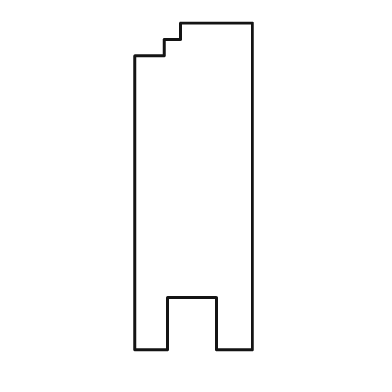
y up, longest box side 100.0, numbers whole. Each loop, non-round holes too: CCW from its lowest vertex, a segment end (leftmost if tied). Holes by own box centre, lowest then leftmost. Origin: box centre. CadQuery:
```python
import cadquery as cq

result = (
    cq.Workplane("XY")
    .moveTo(-18.0, -50.0)
    .lineTo(-8.0, -50.0)
    .lineTo(-8.0, -34.0)
    .lineTo(7.0, -34.0)
    .lineTo(7.0, -50.0)
    .lineTo(18.0, -50.0)
    .lineTo(18.0, 50.0)
    .lineTo(-4.0, 50.0)
    .lineTo(-4.0, 45.0)
    .lineTo(-9.0, 45.0)
    .lineTo(-9.0, 40.0)
    .lineTo(-18.0, 40.0)
    .close()
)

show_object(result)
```